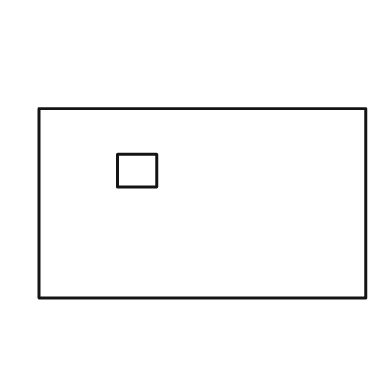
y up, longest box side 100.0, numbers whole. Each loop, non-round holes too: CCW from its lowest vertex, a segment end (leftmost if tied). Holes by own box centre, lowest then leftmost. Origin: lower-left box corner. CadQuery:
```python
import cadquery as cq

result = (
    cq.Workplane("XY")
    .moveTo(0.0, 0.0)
    .lineTo(100.0, 0.0)
    .lineTo(100.0, 58.0)
    .lineTo(0.0, 58.0)
    .close()
    .moveTo(24.0, 34.0)
    .lineTo(36.0, 34.0)
    .lineTo(36.0, 44.0)
    .lineTo(24.0, 44.0)
    .close()
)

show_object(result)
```